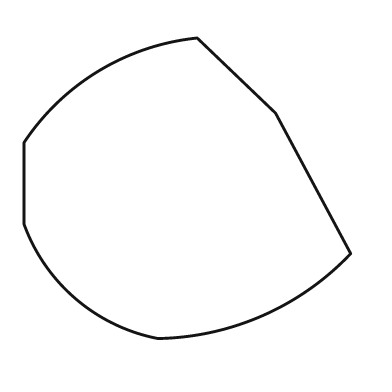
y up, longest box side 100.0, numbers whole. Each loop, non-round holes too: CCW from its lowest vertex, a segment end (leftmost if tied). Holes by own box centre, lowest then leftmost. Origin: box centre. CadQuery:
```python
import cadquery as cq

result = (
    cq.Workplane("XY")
    .moveTo(-9.0, -46.0)
    .threePointArc((23.0, -39.0), (50.0, -20.0))
    .lineTo(27.0, 23.0)
    .lineTo(3.0, 46.0)
    .threePointArc((-27.0, 36.0), (-50.0, 14.0))
    .lineTo(-50.0, -11.0)
    .threePointArc((-34.0, -34.0), (-9.0, -46.0))
    .close()
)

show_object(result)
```